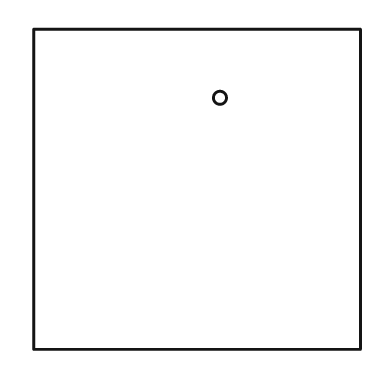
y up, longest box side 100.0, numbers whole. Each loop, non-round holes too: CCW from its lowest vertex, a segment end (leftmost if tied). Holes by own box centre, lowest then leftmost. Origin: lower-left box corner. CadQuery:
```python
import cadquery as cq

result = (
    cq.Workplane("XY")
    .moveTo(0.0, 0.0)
    .lineTo(100.0, 0.0)
    .lineTo(100.0, 98.0)
    .lineTo(0.0, 98.0)
    .close()
    .moveTo(57.0, 77.0)
    .circle(2.0)
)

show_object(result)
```